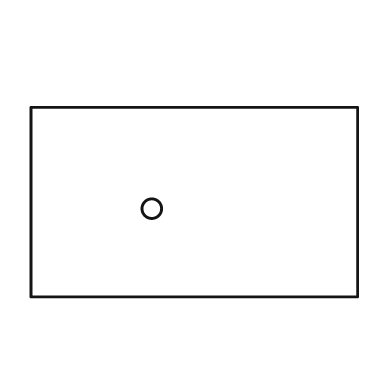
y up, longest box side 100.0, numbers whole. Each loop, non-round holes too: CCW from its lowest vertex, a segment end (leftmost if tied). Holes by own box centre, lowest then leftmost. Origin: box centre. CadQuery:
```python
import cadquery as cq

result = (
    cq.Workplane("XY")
    .moveTo(-50.0, -29.0)
    .lineTo(50.0, -29.0)
    .lineTo(50.0, 29.0)
    .lineTo(-50.0, 29.0)
    .close()
    .moveTo(-13.0, -2.0)
    .circle(3.0)
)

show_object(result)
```